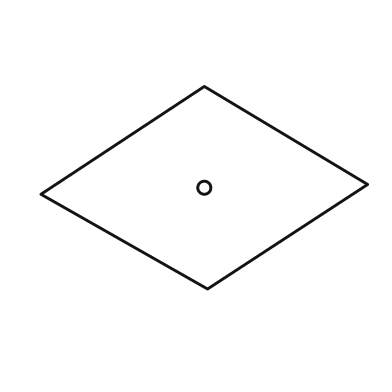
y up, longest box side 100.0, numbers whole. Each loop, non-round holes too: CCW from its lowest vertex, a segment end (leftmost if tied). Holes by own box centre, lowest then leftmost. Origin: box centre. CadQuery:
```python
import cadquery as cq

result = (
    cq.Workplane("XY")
    .moveTo(1.0, -31.0)
    .lineTo(50.0, 1.0)
    .lineTo(0.0, 31.0)
    .lineTo(-50.0, -2.0)
    .close()
    .moveTo(0.0, 0.0)
    .circle(2.0)
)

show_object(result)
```